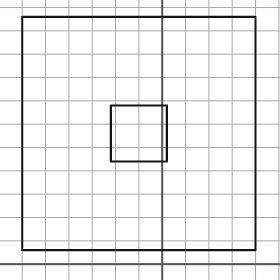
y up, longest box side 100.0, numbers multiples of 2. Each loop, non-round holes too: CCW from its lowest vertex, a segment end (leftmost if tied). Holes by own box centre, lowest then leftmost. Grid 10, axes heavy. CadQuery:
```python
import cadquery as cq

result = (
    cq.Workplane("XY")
    .moveTo(-60.0, 6.0)
    .lineTo(40.0, 6.0)
    .lineTo(40.0, 106.0)
    .lineTo(-60.0, 106.0)
    .close()
    .moveTo(-22.0, 44.0)
    .lineTo(2.0, 44.0)
    .lineTo(2.0, 68.0)
    .lineTo(-22.0, 68.0)
    .close()
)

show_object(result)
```